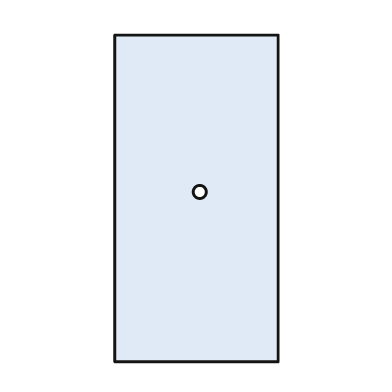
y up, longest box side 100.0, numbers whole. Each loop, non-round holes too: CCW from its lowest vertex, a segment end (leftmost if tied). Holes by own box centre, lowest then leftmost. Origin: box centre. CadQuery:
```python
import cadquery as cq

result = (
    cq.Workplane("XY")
    .moveTo(-25.0, -50.0)
    .lineTo(25.0, -50.0)
    .lineTo(25.0, 50.0)
    .lineTo(-25.0, 50.0)
    .close()
    .moveTo(1.0, 2.0)
    .circle(2.0)
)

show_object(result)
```